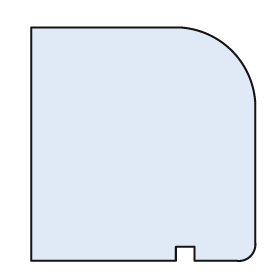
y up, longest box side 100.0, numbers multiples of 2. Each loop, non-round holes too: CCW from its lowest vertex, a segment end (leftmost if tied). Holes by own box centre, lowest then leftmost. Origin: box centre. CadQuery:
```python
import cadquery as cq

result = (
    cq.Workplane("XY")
    .moveTo(-48.0, -50.0)
    .lineTo(14.0, -50.0)
    .lineTo(14.0, -44.0)
    .lineTo(22.0, -44.0)
    .lineTo(22.0, -50.0)
    .lineTo(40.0, -50.0)
    .threePointArc((46.0, -48.0), (48.0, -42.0))
    .lineTo(48.0, 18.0)
    .threePointArc((38.0, 40.0), (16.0, 50.0))
    .lineTo(-48.0, 50.0)
    .close()
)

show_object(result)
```